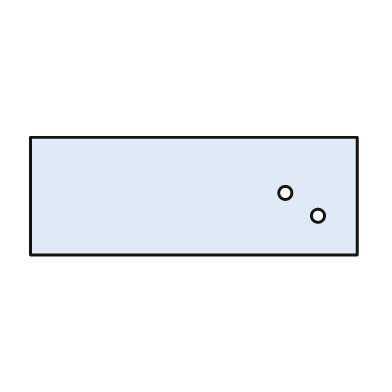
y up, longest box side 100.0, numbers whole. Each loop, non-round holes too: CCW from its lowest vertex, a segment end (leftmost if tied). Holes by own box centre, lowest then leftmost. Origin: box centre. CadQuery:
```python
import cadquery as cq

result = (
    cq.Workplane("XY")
    .moveTo(-50.0, -18.0)
    .lineTo(50.0, -18.0)
    .lineTo(50.0, 18.0)
    .lineTo(-50.0, 18.0)
    .close()
    .moveTo(38.0, -6.0)
    .circle(2.0)
    .moveTo(28.0, 1.0)
    .circle(2.0)
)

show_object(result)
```